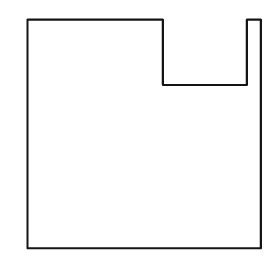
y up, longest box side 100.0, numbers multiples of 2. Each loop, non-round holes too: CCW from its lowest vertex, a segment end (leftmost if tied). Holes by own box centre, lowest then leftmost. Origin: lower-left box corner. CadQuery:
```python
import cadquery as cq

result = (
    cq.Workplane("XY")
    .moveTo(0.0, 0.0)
    .lineTo(100.0, 0.0)
    .lineTo(100.0, 98.0)
    .lineTo(94.0, 98.0)
    .lineTo(94.0, 70.0)
    .lineTo(58.0, 70.0)
    .lineTo(58.0, 98.0)
    .lineTo(0.0, 98.0)
    .close()
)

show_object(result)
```